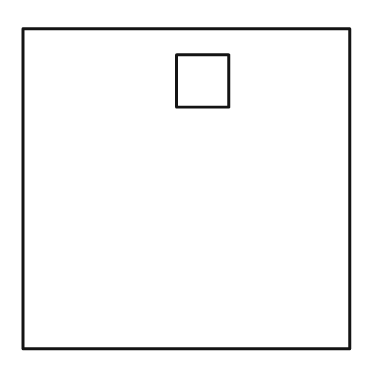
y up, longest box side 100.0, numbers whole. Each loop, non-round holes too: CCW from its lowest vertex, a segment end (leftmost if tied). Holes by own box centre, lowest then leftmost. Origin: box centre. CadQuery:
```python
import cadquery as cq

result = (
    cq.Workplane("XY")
    .moveTo(-50.0, -49.0)
    .lineTo(50.0, -49.0)
    .lineTo(50.0, 49.0)
    .lineTo(-50.0, 49.0)
    .close()
    .moveTo(-3.0, 25.0)
    .lineTo(13.0, 25.0)
    .lineTo(13.0, 41.0)
    .lineTo(-3.0, 41.0)
    .close()
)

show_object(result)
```